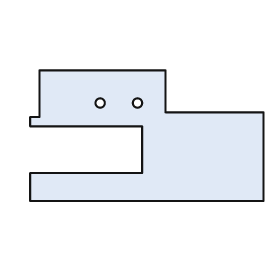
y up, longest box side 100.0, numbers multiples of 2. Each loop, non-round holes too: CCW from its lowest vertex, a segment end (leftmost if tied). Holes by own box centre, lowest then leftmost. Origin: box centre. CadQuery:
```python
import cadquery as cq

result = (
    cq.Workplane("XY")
    .moveTo(-50.0, -28.0)
    .lineTo(50.0, -28.0)
    .lineTo(50.0, 10.0)
    .lineTo(8.0, 10.0)
    .lineTo(8.0, 28.0)
    .lineTo(-46.0, 28.0)
    .lineTo(-46.0, 8.0)
    .lineTo(-50.0, 8.0)
    .lineTo(-50.0, 4.0)
    .lineTo(-2.0, 4.0)
    .lineTo(-2.0, -16.0)
    .lineTo(-50.0, -16.0)
    .close()
    .moveTo(-20.0, 14.0)
    .circle(2.0)
    .moveTo(-4.0, 14.0)
    .circle(2.0)
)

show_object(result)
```